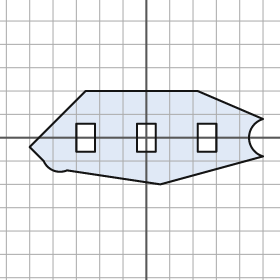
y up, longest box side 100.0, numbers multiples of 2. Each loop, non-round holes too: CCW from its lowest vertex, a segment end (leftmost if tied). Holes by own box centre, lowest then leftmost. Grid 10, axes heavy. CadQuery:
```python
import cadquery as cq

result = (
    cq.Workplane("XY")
    .moveTo(6.0, -20.0)
    .lineTo(50.0, -8.0)
    .threePointArc((44.0, 0.0), (50.0, 8.0))
    .lineTo(22.0, 20.0)
    .lineTo(-26.0, 20.0)
    .lineTo(-50.0, -4.0)
    .lineTo(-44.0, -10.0)
    .threePointArc((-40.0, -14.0), (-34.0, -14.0))
    .close()
    .moveTo(-30.0, -6.0)
    .lineTo(-22.0, -6.0)
    .lineTo(-22.0, 6.0)
    .lineTo(-30.0, 6.0)
    .close()
    .moveTo(-4.0, -6.0)
    .lineTo(4.0, -6.0)
    .lineTo(4.0, 6.0)
    .lineTo(-4.0, 6.0)
    .close()
    .moveTo(22.0, -6.0)
    .lineTo(30.0, -6.0)
    .lineTo(30.0, 6.0)
    .lineTo(22.0, 6.0)
    .close()
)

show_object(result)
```